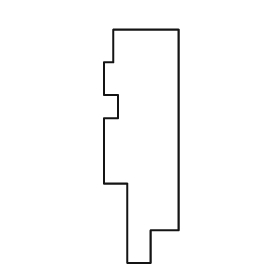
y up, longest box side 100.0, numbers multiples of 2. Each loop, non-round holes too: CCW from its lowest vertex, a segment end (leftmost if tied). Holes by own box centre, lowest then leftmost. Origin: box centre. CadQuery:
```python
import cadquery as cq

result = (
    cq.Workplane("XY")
    .moveTo(-6.0, -50.0)
    .lineTo(4.0, -50.0)
    .lineTo(4.0, -36.0)
    .lineTo(16.0, -36.0)
    .lineTo(16.0, 50.0)
    .lineTo(-12.0, 50.0)
    .lineTo(-12.0, 36.0)
    .lineTo(-16.0, 36.0)
    .lineTo(-16.0, 22.0)
    .lineTo(-10.0, 22.0)
    .lineTo(-10.0, 12.0)
    .lineTo(-16.0, 12.0)
    .lineTo(-16.0, -16.0)
    .lineTo(-6.0, -16.0)
    .close()
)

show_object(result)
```